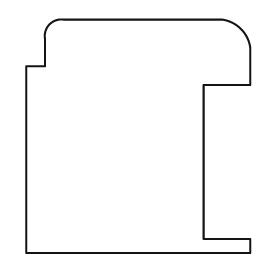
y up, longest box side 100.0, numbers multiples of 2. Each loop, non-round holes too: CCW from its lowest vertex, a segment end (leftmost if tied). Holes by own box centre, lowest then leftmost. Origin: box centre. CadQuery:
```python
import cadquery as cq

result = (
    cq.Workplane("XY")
    .moveTo(-48.0, -50.0)
    .lineTo(48.0, -50.0)
    .lineTo(48.0, -44.0)
    .lineTo(28.0, -44.0)
    .lineTo(28.0, 22.0)
    .lineTo(48.0, 22.0)
    .lineTo(48.0, 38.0)
    .threePointArc((44.0, 46.0), (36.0, 50.0))
    .lineTo(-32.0, 50.0)
    .threePointArc((-38.0, 48.0), (-40.0, 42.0))
    .lineTo(-40.0, 30.0)
    .lineTo(-48.0, 30.0)
    .close()
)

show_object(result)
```